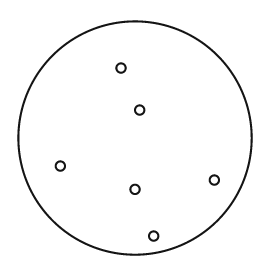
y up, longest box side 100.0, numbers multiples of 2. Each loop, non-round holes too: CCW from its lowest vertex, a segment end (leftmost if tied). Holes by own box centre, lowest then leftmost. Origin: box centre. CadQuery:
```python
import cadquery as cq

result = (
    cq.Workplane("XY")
    .moveTo(0.0, 0.0)
    .circle(50.0)
    .moveTo(8.0, -42.0)
    .circle(2.0)
    .moveTo(0.0, -22.0)
    .circle(2.0)
    .moveTo(34.0, -18.0)
    .circle(2.0)
    .moveTo(-32.0, -12.0)
    .circle(2.0)
    .moveTo(2.0, 12.0)
    .circle(2.0)
    .moveTo(-6.0, 30.0)
    .circle(2.0)
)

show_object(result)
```